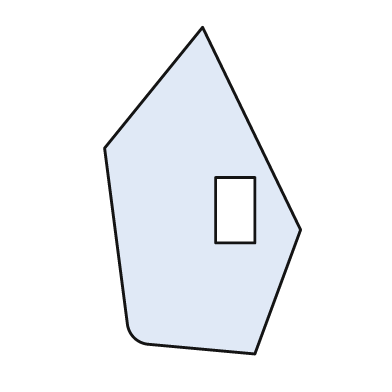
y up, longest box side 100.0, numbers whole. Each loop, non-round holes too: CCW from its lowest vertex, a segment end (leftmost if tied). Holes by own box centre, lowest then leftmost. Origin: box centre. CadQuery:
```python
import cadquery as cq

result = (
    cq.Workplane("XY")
    .moveTo(16.0, -50.0)
    .lineTo(30.0, -12.0)
    .lineTo(0.0, 50.0)
    .lineTo(-30.0, 13.0)
    .lineTo(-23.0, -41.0)
    .threePointArc((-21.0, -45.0), (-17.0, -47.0))
    .close()
    .moveTo(4.0, -16.0)
    .lineTo(16.0, -16.0)
    .lineTo(16.0, 4.0)
    .lineTo(4.0, 4.0)
    .close()
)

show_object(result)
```